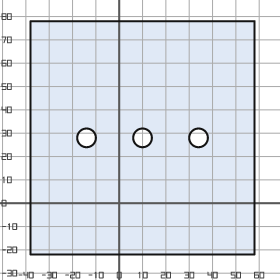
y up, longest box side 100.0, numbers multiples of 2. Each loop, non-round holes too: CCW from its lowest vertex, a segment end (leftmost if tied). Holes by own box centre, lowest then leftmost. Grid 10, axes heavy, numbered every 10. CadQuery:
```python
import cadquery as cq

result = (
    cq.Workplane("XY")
    .moveTo(-38.0, -22.0)
    .lineTo(58.0, -22.0)
    .lineTo(58.0, 78.0)
    .lineTo(-38.0, 78.0)
    .close()
    .moveTo(-14.0, 28.0)
    .circle(4.0)
    .moveTo(10.0, 28.0)
    .circle(4.0)
    .moveTo(34.0, 28.0)
    .circle(4.0)
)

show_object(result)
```